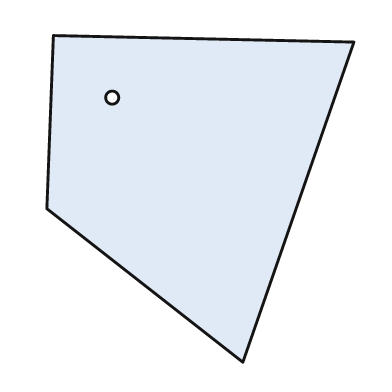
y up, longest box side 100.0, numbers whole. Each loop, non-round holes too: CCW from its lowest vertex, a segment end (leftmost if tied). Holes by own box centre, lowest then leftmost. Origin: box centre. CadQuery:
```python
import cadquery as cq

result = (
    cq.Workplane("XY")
    .moveTo(13.0, -50.0)
    .lineTo(47.0, 48.0)
    .lineTo(-45.0, 50.0)
    .lineTo(-47.0, -3.0)
    .close()
    .moveTo(-27.0, 31.0)
    .circle(2.0)
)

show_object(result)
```